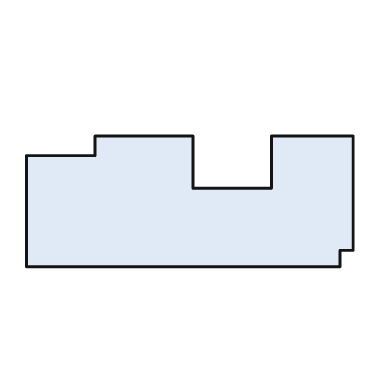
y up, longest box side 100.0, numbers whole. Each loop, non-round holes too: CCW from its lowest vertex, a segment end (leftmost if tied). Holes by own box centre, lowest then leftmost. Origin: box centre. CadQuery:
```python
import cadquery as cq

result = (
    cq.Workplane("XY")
    .moveTo(-50.0, -20.0)
    .lineTo(46.0, -20.0)
    .lineTo(46.0, -15.0)
    .lineTo(50.0, -15.0)
    .lineTo(50.0, 20.0)
    .lineTo(25.0, 20.0)
    .lineTo(25.0, 4.0)
    .lineTo(1.0, 4.0)
    .lineTo(1.0, 20.0)
    .lineTo(-29.0, 20.0)
    .lineTo(-29.0, 14.0)
    .lineTo(-50.0, 14.0)
    .close()
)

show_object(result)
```